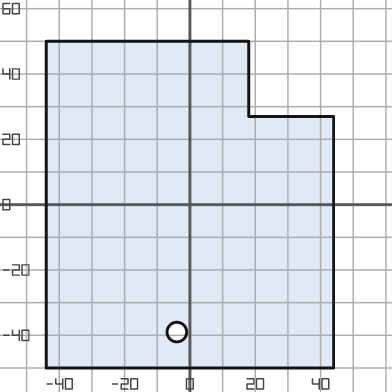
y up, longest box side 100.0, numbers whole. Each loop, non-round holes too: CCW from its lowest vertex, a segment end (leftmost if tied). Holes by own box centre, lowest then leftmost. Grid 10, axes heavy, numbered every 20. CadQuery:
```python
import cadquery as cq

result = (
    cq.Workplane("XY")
    .moveTo(-44.0, -50.0)
    .lineTo(44.0, -50.0)
    .lineTo(44.0, 27.0)
    .lineTo(18.0, 27.0)
    .lineTo(18.0, 50.0)
    .lineTo(-44.0, 50.0)
    .close()
    .moveTo(-4.0, -39.0)
    .circle(3.0)
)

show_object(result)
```